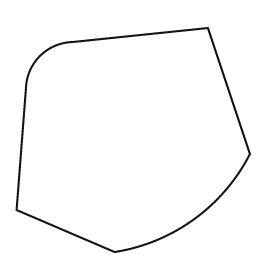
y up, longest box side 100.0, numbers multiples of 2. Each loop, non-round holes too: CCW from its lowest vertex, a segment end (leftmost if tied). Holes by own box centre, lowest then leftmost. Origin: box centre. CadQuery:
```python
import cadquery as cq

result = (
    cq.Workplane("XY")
    .moveTo(-8.0, -48.0)
    .threePointArc((26.0, -34.0), (50.0, -6.0))
    .lineTo(32.0, 48.0)
    .lineTo(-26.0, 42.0)
    .threePointArc((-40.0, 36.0), (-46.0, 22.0))
    .lineTo(-50.0, -30.0)
    .close()
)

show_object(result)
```